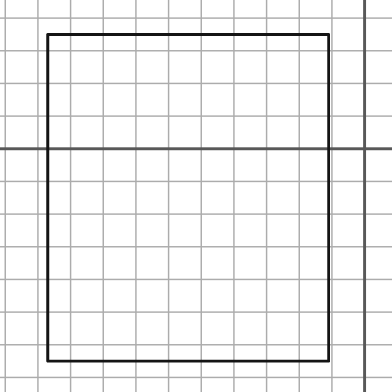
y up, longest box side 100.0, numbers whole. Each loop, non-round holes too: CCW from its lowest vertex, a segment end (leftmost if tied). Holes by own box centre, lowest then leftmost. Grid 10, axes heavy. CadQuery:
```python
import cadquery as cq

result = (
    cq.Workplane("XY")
    .moveTo(-97.0, -65.0)
    .lineTo(-11.0, -65.0)
    .lineTo(-11.0, 35.0)
    .lineTo(-97.0, 35.0)
    .close()
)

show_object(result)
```